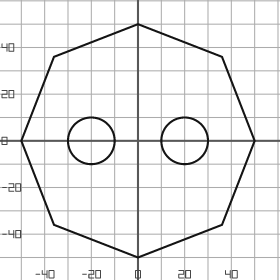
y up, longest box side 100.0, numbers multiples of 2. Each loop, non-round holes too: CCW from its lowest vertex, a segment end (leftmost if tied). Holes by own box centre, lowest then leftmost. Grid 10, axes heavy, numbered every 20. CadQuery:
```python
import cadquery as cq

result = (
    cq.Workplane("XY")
    .moveTo(0.0, -50.0)
    .lineTo(36.0, -36.0)
    .lineTo(50.0, 0.0)
    .lineTo(36.0, 36.0)
    .lineTo(0.0, 50.0)
    .lineTo(-36.0, 36.0)
    .lineTo(-50.0, 0.0)
    .lineTo(-36.0, -36.0)
    .close()
    .moveTo(-20.0, 0.0)
    .circle(10.0)
    .moveTo(20.0, 0.0)
    .circle(10.0)
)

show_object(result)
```